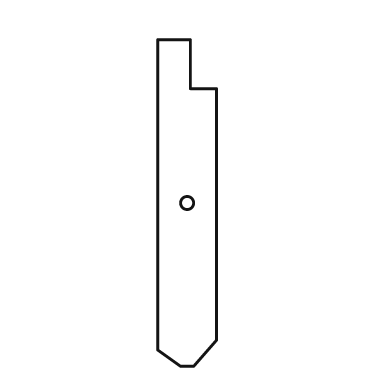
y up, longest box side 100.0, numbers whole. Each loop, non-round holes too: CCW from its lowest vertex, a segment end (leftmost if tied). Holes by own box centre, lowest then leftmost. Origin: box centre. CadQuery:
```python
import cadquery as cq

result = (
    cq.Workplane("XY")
    .moveTo(-2.0, -50.0)
    .lineTo(2.0, -50.0)
    .lineTo(9.0, -42.0)
    .lineTo(9.0, 35.0)
    .lineTo(1.0, 35.0)
    .lineTo(1.0, 50.0)
    .lineTo(-9.0, 50.0)
    .lineTo(-9.0, -45.0)
    .close()
    .moveTo(0.0, 0.0)
    .circle(2.0)
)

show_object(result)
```